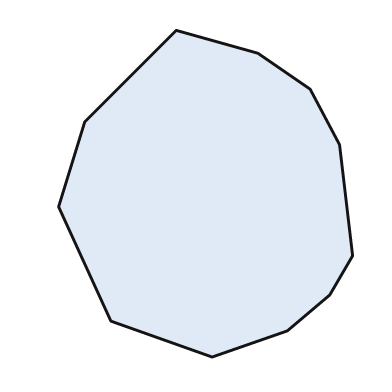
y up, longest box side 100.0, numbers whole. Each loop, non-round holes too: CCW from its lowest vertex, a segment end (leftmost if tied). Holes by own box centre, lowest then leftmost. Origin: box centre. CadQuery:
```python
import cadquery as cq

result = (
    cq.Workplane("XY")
    .moveTo(2.0, -50.0)
    .lineTo(25.0, -42.0)
    .lineTo(38.0, -31.0)
    .lineTo(45.0, -19.0)
    .lineTo(41.0, 15.0)
    .lineTo(32.0, 32.0)
    .lineTo(16.0, 43.0)
    .lineTo(-9.0, 50.0)
    .lineTo(-37.0, 22.0)
    .lineTo(-45.0, -4.0)
    .lineTo(-29.0, -39.0)
    .close()
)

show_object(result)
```